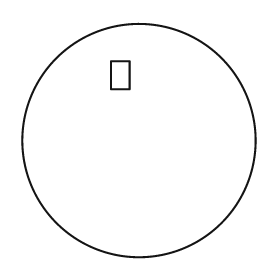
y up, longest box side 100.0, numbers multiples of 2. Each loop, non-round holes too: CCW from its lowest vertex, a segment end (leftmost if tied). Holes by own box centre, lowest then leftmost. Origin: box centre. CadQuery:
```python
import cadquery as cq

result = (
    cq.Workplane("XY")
    .moveTo(0.0, 0.0)
    .circle(50.0)
    .moveTo(-12.0, 22.0)
    .lineTo(-4.0, 22.0)
    .lineTo(-4.0, 34.0)
    .lineTo(-12.0, 34.0)
    .close()
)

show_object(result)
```